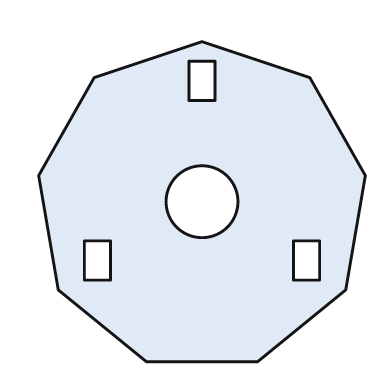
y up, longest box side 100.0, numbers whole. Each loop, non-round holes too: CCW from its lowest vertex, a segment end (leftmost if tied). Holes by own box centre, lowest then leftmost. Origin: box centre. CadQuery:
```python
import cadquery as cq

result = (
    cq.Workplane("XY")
    .moveTo(-17.0, -49.0)
    .lineTo(17.0, -49.0)
    .lineTo(44.0, -27.0)
    .lineTo(50.0, 8.0)
    .lineTo(33.0, 38.0)
    .lineTo(0.0, 49.0)
    .lineTo(-33.0, 38.0)
    .lineTo(-50.0, 8.0)
    .lineTo(-44.0, -27.0)
    .close()
    .moveTo(-36.0, -24.0)
    .lineTo(-28.0, -24.0)
    .lineTo(-28.0, -12.0)
    .lineTo(-36.0, -12.0)
    .close()
    .moveTo(28.0, -24.0)
    .lineTo(36.0, -24.0)
    .lineTo(36.0, -12.0)
    .lineTo(28.0, -12.0)
    .close()
    .moveTo(0.0, 0.0)
    .circle(11.0)
    .moveTo(-4.0, 31.0)
    .lineTo(4.0, 31.0)
    .lineTo(4.0, 43.0)
    .lineTo(-4.0, 43.0)
    .close()
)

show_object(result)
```